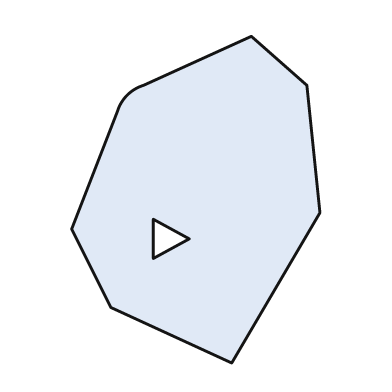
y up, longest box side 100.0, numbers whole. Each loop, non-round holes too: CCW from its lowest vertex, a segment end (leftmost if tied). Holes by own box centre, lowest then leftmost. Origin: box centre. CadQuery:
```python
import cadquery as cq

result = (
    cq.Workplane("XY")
    .moveTo(11.0, -50.0)
    .lineTo(38.0, -4.0)
    .lineTo(34.0, 35.0)
    .lineTo(17.0, 50.0)
    .lineTo(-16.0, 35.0)
    .threePointArc((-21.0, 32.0), (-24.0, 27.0))
    .lineTo(-38.0, -9.0)
    .lineTo(-26.0, -33.0)
    .close()
    .moveTo(-13.0, -18.0)
    .lineTo(-2.0, -12.0)
    .lineTo(-13.0, -6.0)
    .close()
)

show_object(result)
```